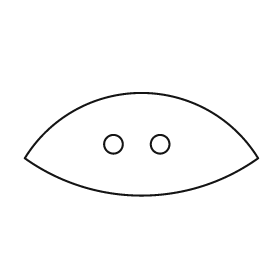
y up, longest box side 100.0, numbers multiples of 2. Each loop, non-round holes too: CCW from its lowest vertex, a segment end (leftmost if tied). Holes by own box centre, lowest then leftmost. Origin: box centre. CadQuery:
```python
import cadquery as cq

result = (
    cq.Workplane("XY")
    .moveTo(-50.0, -6.0)
    .threePointArc((0.0, -22.0), (50.0, -6.0))
    .threePointArc((0.0, 22.0), (-50.0, -6.0))
    .close()
    .moveTo(-12.0, 0.0)
    .circle(4.0)
    .moveTo(8.0, 0.0)
    .circle(4.0)
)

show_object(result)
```